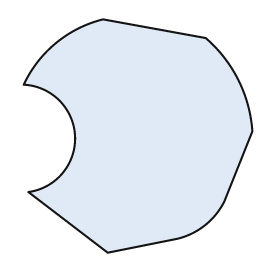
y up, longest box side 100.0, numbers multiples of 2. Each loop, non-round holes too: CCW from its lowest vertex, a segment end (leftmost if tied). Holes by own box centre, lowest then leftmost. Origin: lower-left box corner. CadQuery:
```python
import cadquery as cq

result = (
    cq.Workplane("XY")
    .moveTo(36.0, 0.0)
    .lineTo(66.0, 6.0)
    .threePointArc((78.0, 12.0), (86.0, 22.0))
    .lineTo(98.0, 52.0)
    .threePointArc((92.0, 74.0), (78.0, 92.0))
    .lineTo(34.0, 100.0)
    .threePointArc((14.0, 90.0), (0.0, 72.0))
    .threePointArc((22.0, 50.0), (2.0, 26.0))
    .close()
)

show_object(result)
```